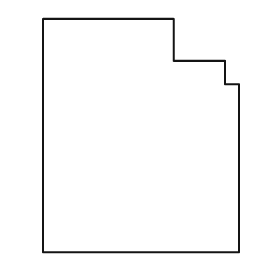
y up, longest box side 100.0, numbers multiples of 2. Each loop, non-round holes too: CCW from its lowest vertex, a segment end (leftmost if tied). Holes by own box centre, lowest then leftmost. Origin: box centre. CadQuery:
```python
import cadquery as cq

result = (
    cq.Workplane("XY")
    .moveTo(-42.0, -50.0)
    .lineTo(42.0, -50.0)
    .lineTo(42.0, 22.0)
    .lineTo(36.0, 22.0)
    .lineTo(36.0, 32.0)
    .lineTo(14.0, 32.0)
    .lineTo(14.0, 50.0)
    .lineTo(-42.0, 50.0)
    .close()
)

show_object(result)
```